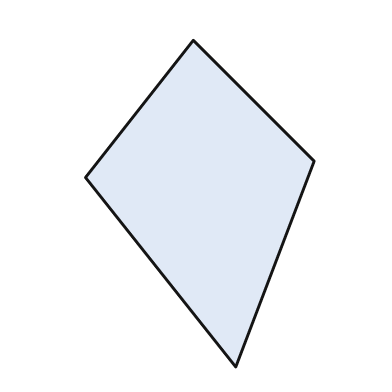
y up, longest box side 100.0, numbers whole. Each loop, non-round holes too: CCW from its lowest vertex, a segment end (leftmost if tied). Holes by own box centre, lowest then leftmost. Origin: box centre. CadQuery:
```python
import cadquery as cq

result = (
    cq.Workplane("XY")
    .moveTo(11.0, -50.0)
    .lineTo(35.0, 13.0)
    .lineTo(-2.0, 50.0)
    .lineTo(-35.0, 8.0)
    .close()
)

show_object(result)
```